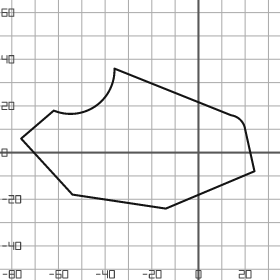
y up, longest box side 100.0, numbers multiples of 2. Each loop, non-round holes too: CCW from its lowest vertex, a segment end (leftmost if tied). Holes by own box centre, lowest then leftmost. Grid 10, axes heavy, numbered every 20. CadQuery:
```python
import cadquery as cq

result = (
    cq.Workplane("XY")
    .moveTo(-14.0, -24.0)
    .lineTo(24.0, -8.0)
    .lineTo(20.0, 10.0)
    .threePointArc((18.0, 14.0), (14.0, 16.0))
    .lineTo(-36.0, 36.0)
    .threePointArc((-44.0, 20.0), (-62.0, 18.0))
    .lineTo(-76.0, 6.0)
    .lineTo(-54.0, -18.0)
    .close()
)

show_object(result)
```